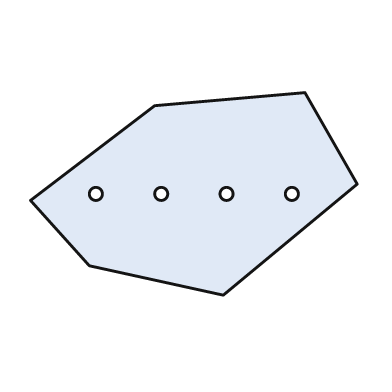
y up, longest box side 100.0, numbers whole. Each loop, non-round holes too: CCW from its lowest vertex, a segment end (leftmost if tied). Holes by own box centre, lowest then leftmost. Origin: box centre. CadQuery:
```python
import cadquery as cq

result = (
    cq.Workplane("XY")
    .moveTo(9.0, -31.0)
    .lineTo(50.0, 3.0)
    .lineTo(34.0, 31.0)
    .lineTo(-12.0, 27.0)
    .lineTo(-50.0, -2.0)
    .lineTo(-32.0, -22.0)
    .close()
    .moveTo(-30.0, 0.0)
    .circle(2.0)
    .moveTo(-10.0, 0.0)
    .circle(2.0)
    .moveTo(10.0, 0.0)
    .circle(2.0)
    .moveTo(30.0, 0.0)
    .circle(2.0)
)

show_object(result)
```